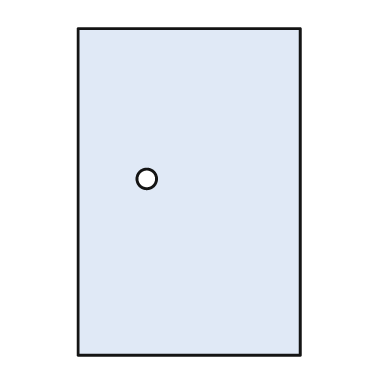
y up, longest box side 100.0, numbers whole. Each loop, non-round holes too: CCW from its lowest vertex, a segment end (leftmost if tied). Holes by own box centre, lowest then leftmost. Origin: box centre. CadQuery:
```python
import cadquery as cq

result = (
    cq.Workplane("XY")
    .moveTo(-34.0, -50.0)
    .lineTo(34.0, -50.0)
    .lineTo(34.0, 50.0)
    .lineTo(-34.0, 50.0)
    .close()
    .moveTo(-13.0, 4.0)
    .circle(3.0)
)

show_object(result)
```